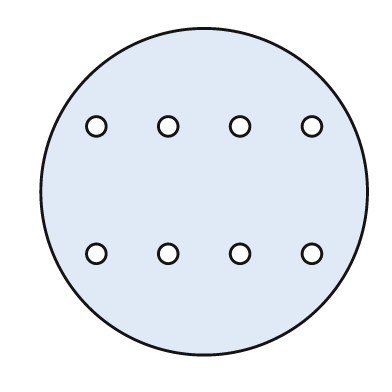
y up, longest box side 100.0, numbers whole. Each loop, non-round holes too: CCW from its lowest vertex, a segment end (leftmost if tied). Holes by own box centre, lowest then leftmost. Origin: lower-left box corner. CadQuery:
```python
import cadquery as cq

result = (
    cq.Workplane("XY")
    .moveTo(50.0, 50.0)
    .circle(50.0)
    .moveTo(17.0, 31.0)
    .circle(3.0)
    .moveTo(39.0, 31.0)
    .circle(3.0)
    .moveTo(61.0, 31.0)
    .circle(3.0)
    .moveTo(83.0, 31.0)
    .circle(3.0)
    .moveTo(17.0, 70.0)
    .circle(3.0)
    .moveTo(39.0, 70.0)
    .circle(3.0)
    .moveTo(61.0, 70.0)
    .circle(3.0)
    .moveTo(83.0, 70.0)
    .circle(3.0)
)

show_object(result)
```